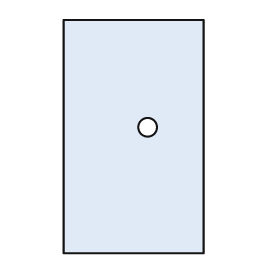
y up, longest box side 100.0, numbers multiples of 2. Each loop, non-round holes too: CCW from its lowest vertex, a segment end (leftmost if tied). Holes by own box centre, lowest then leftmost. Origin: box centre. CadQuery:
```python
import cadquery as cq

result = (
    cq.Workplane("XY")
    .moveTo(-30.0, -50.0)
    .lineTo(30.0, -50.0)
    .lineTo(30.0, 50.0)
    .lineTo(-30.0, 50.0)
    .close()
    .moveTo(6.0, 4.0)
    .circle(4.0)
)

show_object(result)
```